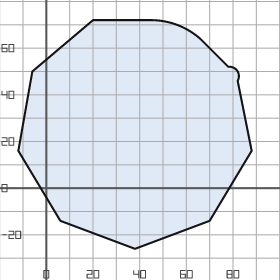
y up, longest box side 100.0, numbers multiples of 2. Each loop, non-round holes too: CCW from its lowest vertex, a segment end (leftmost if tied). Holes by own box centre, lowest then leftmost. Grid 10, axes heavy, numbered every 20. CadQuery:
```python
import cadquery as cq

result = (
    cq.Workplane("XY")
    .moveTo(38.0, -26.0)
    .lineTo(70.0, -14.0)
    .lineTo(88.0, 16.0)
    .lineTo(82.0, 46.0)
    .threePointArc((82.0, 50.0), (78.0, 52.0))
    .lineTo(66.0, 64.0)
    .threePointArc((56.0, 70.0), (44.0, 72.0))
    .lineTo(20.0, 72.0)
    .lineTo(-6.0, 50.0)
    .lineTo(-12.0, 16.0)
    .lineTo(6.0, -14.0)
    .close()
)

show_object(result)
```